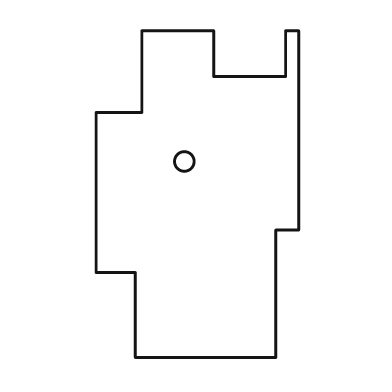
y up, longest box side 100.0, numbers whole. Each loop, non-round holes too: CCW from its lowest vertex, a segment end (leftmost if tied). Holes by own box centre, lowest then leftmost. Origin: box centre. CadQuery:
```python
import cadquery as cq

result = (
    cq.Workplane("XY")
    .moveTo(-19.0, -50.0)
    .lineTo(24.0, -50.0)
    .lineTo(24.0, -11.0)
    .lineTo(31.0, -11.0)
    .lineTo(31.0, 50.0)
    .lineTo(27.0, 50.0)
    .lineTo(27.0, 36.0)
    .lineTo(5.0, 36.0)
    .lineTo(5.0, 50.0)
    .lineTo(-17.0, 50.0)
    .lineTo(-17.0, 25.0)
    .lineTo(-31.0, 25.0)
    .lineTo(-31.0, -24.0)
    .lineTo(-19.0, -24.0)
    .close()
    .moveTo(-4.0, 10.0)
    .circle(3.0)
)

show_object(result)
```